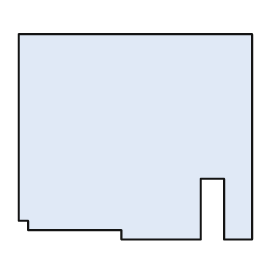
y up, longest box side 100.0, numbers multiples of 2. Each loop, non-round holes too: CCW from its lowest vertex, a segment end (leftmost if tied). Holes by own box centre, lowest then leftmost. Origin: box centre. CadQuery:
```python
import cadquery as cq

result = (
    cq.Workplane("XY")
    .moveTo(-6.0, -44.0)
    .lineTo(28.0, -44.0)
    .lineTo(28.0, -18.0)
    .lineTo(38.0, -18.0)
    .lineTo(38.0, -44.0)
    .lineTo(50.0, -44.0)
    .lineTo(50.0, 44.0)
    .lineTo(-50.0, 44.0)
    .lineTo(-50.0, -36.0)
    .lineTo(-46.0, -36.0)
    .lineTo(-46.0, -40.0)
    .lineTo(-6.0, -40.0)
    .close()
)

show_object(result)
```